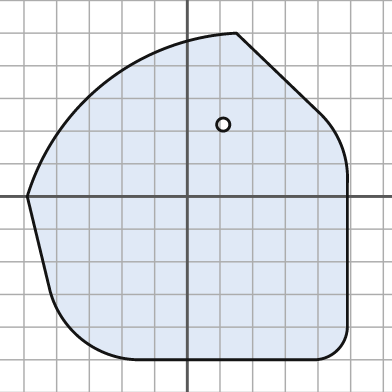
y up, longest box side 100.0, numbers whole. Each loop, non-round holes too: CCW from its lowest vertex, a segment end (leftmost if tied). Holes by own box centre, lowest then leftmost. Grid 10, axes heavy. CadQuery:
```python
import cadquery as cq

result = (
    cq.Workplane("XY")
    .moveTo(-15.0, -50.0)
    .lineTo(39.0, -50.0)
    .threePointArc((46.0, -47.0), (49.0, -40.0))
    .lineTo(49.0, 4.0)
    .threePointArc((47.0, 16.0), (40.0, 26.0))
    .lineTo(15.0, 50.0)
    .threePointArc((-25.0, 35.0), (-49.0, 0.0))
    .lineTo(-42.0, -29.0)
    .threePointArc((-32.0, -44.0), (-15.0, -50.0))
    .close()
    .moveTo(11.0, 22.0)
    .circle(2.0)
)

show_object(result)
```